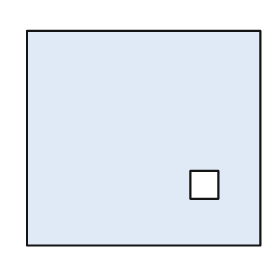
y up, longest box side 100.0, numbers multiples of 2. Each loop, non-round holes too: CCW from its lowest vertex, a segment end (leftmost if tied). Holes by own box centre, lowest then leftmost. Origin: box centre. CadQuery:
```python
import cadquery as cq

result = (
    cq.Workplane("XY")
    .moveTo(-50.0, -46.0)
    .lineTo(50.0, -46.0)
    .lineTo(50.0, 46.0)
    .lineTo(-50.0, 46.0)
    .close()
    .moveTo(20.0, -26.0)
    .lineTo(32.0, -26.0)
    .lineTo(32.0, -14.0)
    .lineTo(20.0, -14.0)
    .close()
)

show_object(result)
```